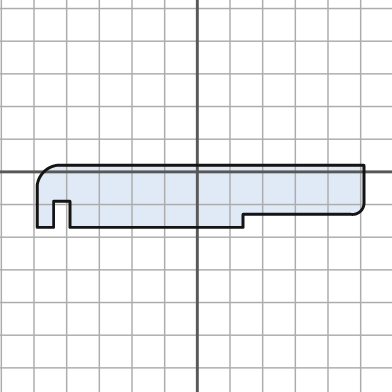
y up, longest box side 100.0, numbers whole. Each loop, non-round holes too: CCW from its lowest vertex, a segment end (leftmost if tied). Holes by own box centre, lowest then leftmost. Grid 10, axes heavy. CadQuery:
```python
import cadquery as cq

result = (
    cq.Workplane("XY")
    .moveTo(-49.0, -17.0)
    .lineTo(-44.0, -17.0)
    .lineTo(-44.0, -9.0)
    .lineTo(-39.0, -9.0)
    .lineTo(-39.0, -17.0)
    .lineTo(14.0, -17.0)
    .lineTo(14.0, -13.0)
    .lineTo(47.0, -13.0)
    .threePointArc((50.0, -12.0), (51.0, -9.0))
    .lineTo(51.0, 2.0)
    .lineTo(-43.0, 2.0)
    .threePointArc((-47.0, 0.0), (-49.0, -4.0))
    .close()
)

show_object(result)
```